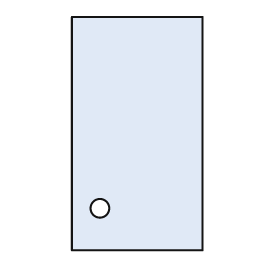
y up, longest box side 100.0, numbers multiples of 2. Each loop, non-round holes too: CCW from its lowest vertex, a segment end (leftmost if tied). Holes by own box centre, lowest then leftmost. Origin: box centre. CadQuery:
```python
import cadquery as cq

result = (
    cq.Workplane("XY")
    .moveTo(-28.0, -50.0)
    .lineTo(28.0, -50.0)
    .lineTo(28.0, 50.0)
    .lineTo(-28.0, 50.0)
    .close()
    .moveTo(-16.0, -32.0)
    .circle(4.0)
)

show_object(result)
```